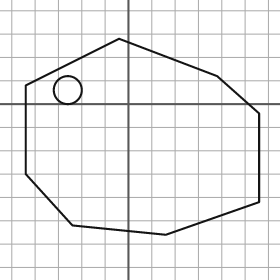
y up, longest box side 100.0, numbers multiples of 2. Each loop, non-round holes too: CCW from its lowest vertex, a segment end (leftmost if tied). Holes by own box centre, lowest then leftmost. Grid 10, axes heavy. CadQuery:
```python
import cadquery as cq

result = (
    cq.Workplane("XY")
    .moveTo(16.0, -56.0)
    .lineTo(56.0, -42.0)
    .lineTo(56.0, -4.0)
    .lineTo(38.0, 12.0)
    .lineTo(-4.0, 28.0)
    .lineTo(-44.0, 8.0)
    .lineTo(-44.0, -30.0)
    .lineTo(-24.0, -52.0)
    .close()
    .moveTo(-26.0, 6.0)
    .circle(6.0)
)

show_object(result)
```